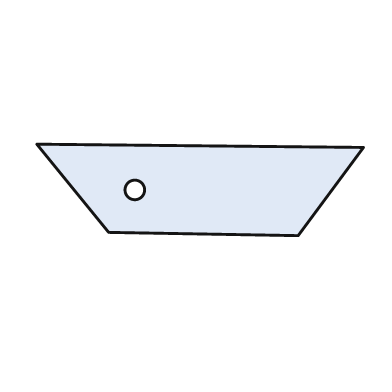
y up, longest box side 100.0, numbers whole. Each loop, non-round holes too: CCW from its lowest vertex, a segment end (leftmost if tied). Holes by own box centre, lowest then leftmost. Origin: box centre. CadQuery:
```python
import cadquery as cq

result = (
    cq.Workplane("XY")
    .moveTo(30.0, -14.0)
    .lineTo(50.0, 13.0)
    .lineTo(-50.0, 14.0)
    .lineTo(-28.0, -13.0)
    .close()
    .moveTo(-20.0, 0.0)
    .circle(3.0)
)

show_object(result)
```